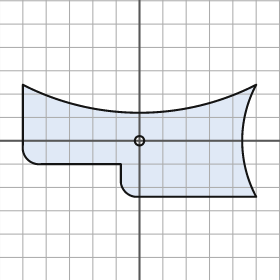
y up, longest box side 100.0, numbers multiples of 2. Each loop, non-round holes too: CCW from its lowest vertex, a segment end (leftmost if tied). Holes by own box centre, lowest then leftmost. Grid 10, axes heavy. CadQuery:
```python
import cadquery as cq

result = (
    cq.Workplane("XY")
    .moveTo(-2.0, -24.0)
    .lineTo(50.0, -24.0)
    .threePointArc((44.0, 0.0), (50.0, 24.0))
    .threePointArc((0.0, 12.0), (-50.0, 24.0))
    .lineTo(-50.0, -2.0)
    .threePointArc((-48.0, -8.0), (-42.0, -10.0))
    .lineTo(-8.0, -10.0)
    .lineTo(-8.0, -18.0)
    .threePointArc((-6.0, -22.0), (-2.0, -24.0))
    .close()
    .moveTo(0.0, 0.0)
    .circle(2.0)
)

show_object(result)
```